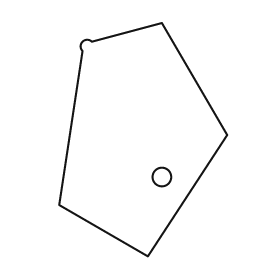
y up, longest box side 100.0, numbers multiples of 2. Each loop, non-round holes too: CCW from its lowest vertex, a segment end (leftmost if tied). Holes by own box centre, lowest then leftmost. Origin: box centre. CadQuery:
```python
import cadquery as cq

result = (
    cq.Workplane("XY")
    .moveTo(2.0, -50.0)
    .lineTo(36.0, 2.0)
    .lineTo(8.0, 50.0)
    .lineTo(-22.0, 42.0)
    .threePointArc((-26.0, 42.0), (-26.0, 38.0))
    .lineTo(-36.0, -28.0)
    .close()
    .moveTo(8.0, -16.0)
    .circle(4.0)
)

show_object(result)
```